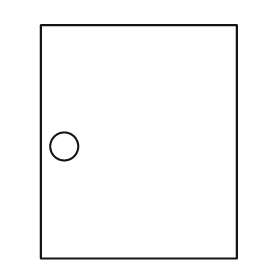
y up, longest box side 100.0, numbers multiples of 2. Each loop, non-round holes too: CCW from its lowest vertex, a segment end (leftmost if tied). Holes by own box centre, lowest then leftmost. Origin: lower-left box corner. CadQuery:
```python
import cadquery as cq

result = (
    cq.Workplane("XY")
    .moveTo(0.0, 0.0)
    .lineTo(84.0, 0.0)
    .lineTo(84.0, 100.0)
    .lineTo(0.0, 100.0)
    .close()
    .moveTo(10.0, 48.0)
    .circle(6.0)
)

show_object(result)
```